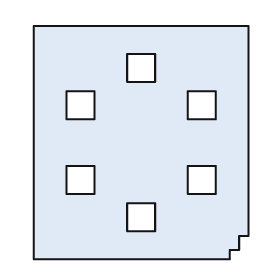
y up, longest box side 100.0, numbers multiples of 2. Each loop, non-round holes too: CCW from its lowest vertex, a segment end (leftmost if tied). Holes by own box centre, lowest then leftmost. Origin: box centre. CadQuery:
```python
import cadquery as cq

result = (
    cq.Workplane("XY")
    .moveTo(-46.0, -50.0)
    .lineTo(38.0, -50.0)
    .lineTo(38.0, -46.0)
    .lineTo(42.0, -46.0)
    .lineTo(42.0, -40.0)
    .lineTo(46.0, -40.0)
    .lineTo(46.0, 50.0)
    .lineTo(-46.0, 50.0)
    .close()
    .moveTo(-6.0, -38.0)
    .lineTo(6.0, -38.0)
    .lineTo(6.0, -26.0)
    .lineTo(-6.0, -26.0)
    .close()
    .moveTo(-32.0, -22.0)
    .lineTo(-20.0, -22.0)
    .lineTo(-20.0, -10.0)
    .lineTo(-32.0, -10.0)
    .close()
    .moveTo(20.0, -22.0)
    .lineTo(32.0, -22.0)
    .lineTo(32.0, -10.0)
    .lineTo(20.0, -10.0)
    .close()
    .moveTo(-32.0, 10.0)
    .lineTo(-20.0, 10.0)
    .lineTo(-20.0, 22.0)
    .lineTo(-32.0, 22.0)
    .close()
    .moveTo(20.0, 10.0)
    .lineTo(32.0, 10.0)
    .lineTo(32.0, 22.0)
    .lineTo(20.0, 22.0)
    .close()
    .moveTo(-6.0, 26.0)
    .lineTo(6.0, 26.0)
    .lineTo(6.0, 38.0)
    .lineTo(-6.0, 38.0)
    .close()
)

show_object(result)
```